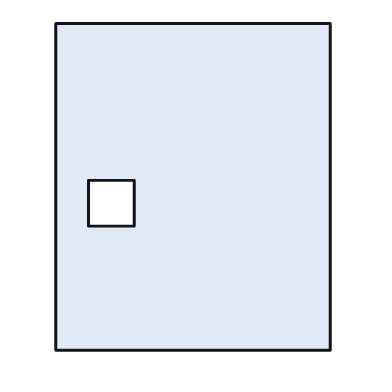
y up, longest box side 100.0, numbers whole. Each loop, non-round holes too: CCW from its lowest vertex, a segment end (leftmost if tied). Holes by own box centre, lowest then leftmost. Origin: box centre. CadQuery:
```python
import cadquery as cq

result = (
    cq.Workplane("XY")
    .moveTo(-42.0, -50.0)
    .lineTo(42.0, -50.0)
    .lineTo(42.0, 50.0)
    .lineTo(-42.0, 50.0)
    .close()
    .moveTo(-32.0, -12.0)
    .lineTo(-18.0, -12.0)
    .lineTo(-18.0, 2.0)
    .lineTo(-32.0, 2.0)
    .close()
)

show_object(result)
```